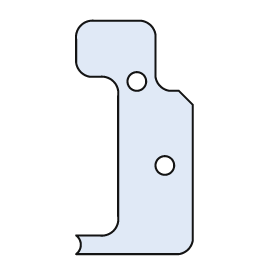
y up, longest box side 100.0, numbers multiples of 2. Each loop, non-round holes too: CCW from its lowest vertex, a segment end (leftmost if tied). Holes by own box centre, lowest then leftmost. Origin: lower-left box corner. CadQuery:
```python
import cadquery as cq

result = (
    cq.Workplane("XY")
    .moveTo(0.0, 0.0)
    .lineTo(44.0, 0.0)
    .threePointArc((48.0, 2.0), (50.0, 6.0))
    .lineTo(50.0, 64.0)
    .lineTo(44.0, 70.0)
    .lineTo(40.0, 70.0)
    .threePointArc((36.0, 72.0), (34.0, 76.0))
    .lineTo(34.0, 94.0)
    .threePointArc((32.0, 98.0), (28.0, 100.0))
    .lineTo(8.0, 100.0)
    .threePointArc((2.0, 98.0), (0.0, 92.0))
    .lineTo(0.0, 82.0)
    .threePointArc((2.0, 78.0), (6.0, 76.0))
    .lineTo(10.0, 76.0)
    .threePointArc((16.0, 74.0), (18.0, 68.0))
    .lineTo(18.0, 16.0)
    .threePointArc((16.0, 10.0), (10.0, 8.0))
    .lineTo(0.0, 8.0)
    .threePointArc((2.0, 4.0), (0.0, 0.0))
    .close()
    .moveTo(38.0, 38.0)
    .circle(4.0)
    .moveTo(26.0, 74.0)
    .circle(4.0)
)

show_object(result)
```